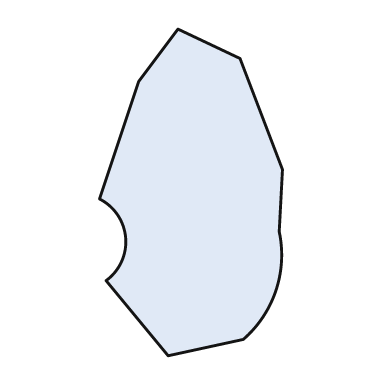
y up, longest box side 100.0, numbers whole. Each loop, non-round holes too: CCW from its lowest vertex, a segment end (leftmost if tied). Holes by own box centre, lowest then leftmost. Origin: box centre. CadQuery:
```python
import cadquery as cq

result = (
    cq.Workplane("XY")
    .moveTo(-7.0, -50.0)
    .lineTo(16.0, -45.0)
    .threePointArc((26.0, -30.0), (27.0, -12.0))
    .lineTo(28.0, 7.0)
    .lineTo(15.0, 41.0)
    .lineTo(-4.0, 50.0)
    .lineTo(-16.0, 34.0)
    .lineTo(-28.0, -2.0)
    .threePointArc((-20.0, -14.0), (-26.0, -27.0))
    .close()
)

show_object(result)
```